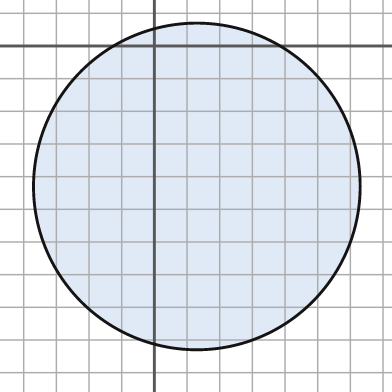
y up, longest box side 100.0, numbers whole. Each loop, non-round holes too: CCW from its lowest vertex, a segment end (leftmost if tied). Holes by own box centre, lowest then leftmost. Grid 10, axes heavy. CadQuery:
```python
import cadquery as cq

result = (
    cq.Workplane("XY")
    .moveTo(13.0, -43.0)
    .circle(50.0)
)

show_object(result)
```